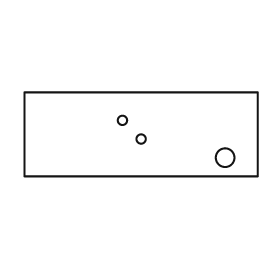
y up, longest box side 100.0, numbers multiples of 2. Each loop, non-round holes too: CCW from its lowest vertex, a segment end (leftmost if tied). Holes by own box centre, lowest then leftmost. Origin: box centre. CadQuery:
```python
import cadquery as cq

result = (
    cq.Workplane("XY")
    .moveTo(-50.0, -18.0)
    .lineTo(50.0, -18.0)
    .lineTo(50.0, 18.0)
    .lineTo(-50.0, 18.0)
    .close()
    .moveTo(36.0, -10.0)
    .circle(4.0)
    .moveTo(0.0, -2.0)
    .circle(2.0)
    .moveTo(-8.0, 6.0)
    .circle(2.0)
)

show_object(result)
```